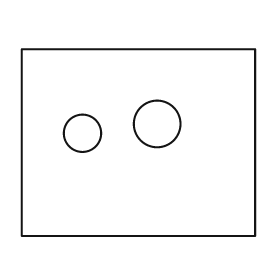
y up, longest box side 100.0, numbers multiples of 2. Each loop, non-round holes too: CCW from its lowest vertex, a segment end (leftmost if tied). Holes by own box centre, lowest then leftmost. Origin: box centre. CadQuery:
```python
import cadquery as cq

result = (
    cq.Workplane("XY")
    .moveTo(-50.0, -40.0)
    .lineTo(50.0, -40.0)
    .lineTo(50.0, 40.0)
    .lineTo(-50.0, 40.0)
    .close()
    .moveTo(-24.0, 4.0)
    .circle(8.0)
    .moveTo(8.0, 8.0)
    .circle(10.0)
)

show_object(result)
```